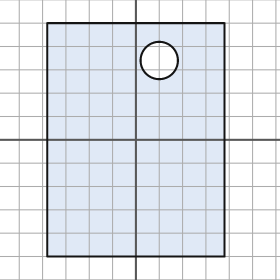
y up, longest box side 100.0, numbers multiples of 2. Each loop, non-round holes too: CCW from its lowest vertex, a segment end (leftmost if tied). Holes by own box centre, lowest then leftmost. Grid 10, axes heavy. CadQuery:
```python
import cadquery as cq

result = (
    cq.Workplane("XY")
    .moveTo(-38.0, -50.0)
    .lineTo(38.0, -50.0)
    .lineTo(38.0, 50.0)
    .lineTo(-38.0, 50.0)
    .close()
    .moveTo(10.0, 34.0)
    .circle(8.0)
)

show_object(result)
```